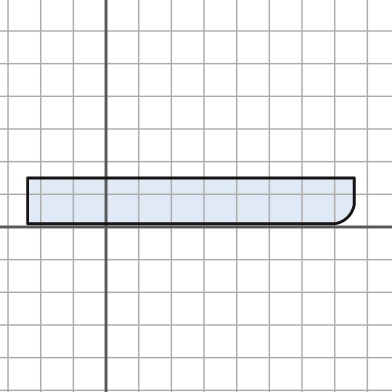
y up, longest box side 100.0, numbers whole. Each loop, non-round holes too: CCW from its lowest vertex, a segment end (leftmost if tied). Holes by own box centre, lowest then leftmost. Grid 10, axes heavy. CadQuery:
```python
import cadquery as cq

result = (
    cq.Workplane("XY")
    .moveTo(-24.0, 1.0)
    .lineTo(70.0, 1.0)
    .threePointArc((74.0, 3.0), (76.0, 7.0))
    .lineTo(76.0, 15.0)
    .lineTo(-24.0, 15.0)
    .close()
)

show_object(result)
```